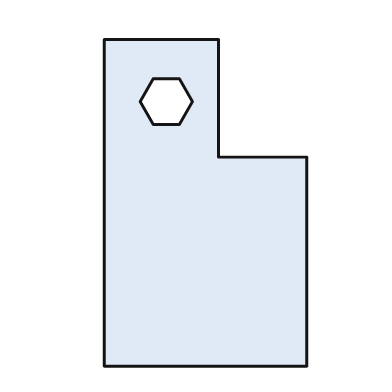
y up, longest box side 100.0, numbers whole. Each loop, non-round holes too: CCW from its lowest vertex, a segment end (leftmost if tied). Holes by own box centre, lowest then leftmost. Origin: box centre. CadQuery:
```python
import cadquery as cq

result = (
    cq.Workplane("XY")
    .moveTo(-31.0, -50.0)
    .lineTo(31.0, -50.0)
    .lineTo(31.0, 14.0)
    .lineTo(4.0, 14.0)
    .lineTo(4.0, 50.0)
    .lineTo(-31.0, 50.0)
    .close()
    .moveTo(-16.0, 24.0)
    .lineTo(-8.0, 24.0)
    .lineTo(-4.0, 31.0)
    .lineTo(-8.0, 38.0)
    .lineTo(-16.0, 38.0)
    .lineTo(-20.0, 31.0)
    .close()
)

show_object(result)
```